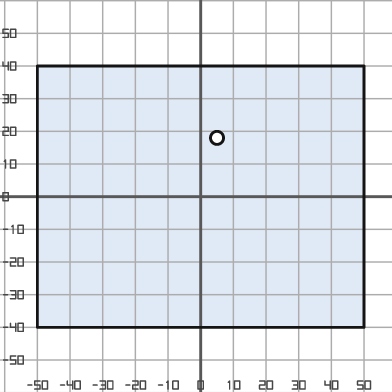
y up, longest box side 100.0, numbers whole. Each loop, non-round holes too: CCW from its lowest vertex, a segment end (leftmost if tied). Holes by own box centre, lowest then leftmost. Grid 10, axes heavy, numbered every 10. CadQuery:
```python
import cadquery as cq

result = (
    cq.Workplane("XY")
    .moveTo(-50.0, -40.0)
    .lineTo(50.0, -40.0)
    .lineTo(50.0, 40.0)
    .lineTo(-50.0, 40.0)
    .close()
    .moveTo(5.0, 18.0)
    .circle(2.0)
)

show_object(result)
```